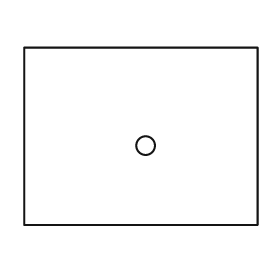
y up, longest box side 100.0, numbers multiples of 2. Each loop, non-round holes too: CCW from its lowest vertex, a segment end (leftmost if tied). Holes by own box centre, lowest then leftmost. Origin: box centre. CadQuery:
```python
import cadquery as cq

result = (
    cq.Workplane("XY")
    .moveTo(-50.0, -38.0)
    .lineTo(50.0, -38.0)
    .lineTo(50.0, 38.0)
    .lineTo(-50.0, 38.0)
    .close()
    .moveTo(2.0, -4.0)
    .circle(4.0)
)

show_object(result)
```